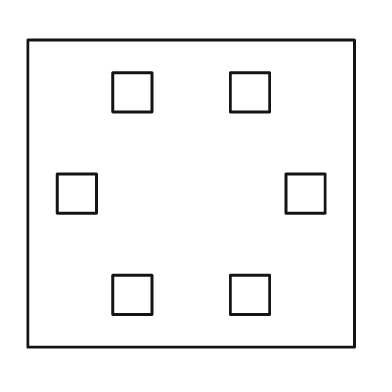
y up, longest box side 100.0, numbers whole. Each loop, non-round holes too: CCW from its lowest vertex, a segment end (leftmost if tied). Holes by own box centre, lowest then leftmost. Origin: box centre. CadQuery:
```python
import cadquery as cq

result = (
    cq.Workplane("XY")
    .moveTo(-50.0, -47.0)
    .lineTo(50.0, -47.0)
    .lineTo(50.0, 47.0)
    .lineTo(-50.0, 47.0)
    .close()
    .moveTo(-24.0, -37.0)
    .lineTo(-12.0, -37.0)
    .lineTo(-12.0, -25.0)
    .lineTo(-24.0, -25.0)
    .close()
    .moveTo(12.0, -37.0)
    .lineTo(24.0, -37.0)
    .lineTo(24.0, -25.0)
    .lineTo(12.0, -25.0)
    .close()
    .moveTo(-41.0, -6.0)
    .lineTo(-29.0, -6.0)
    .lineTo(-29.0, 6.0)
    .lineTo(-41.0, 6.0)
    .close()
    .moveTo(29.0, -6.0)
    .lineTo(41.0, -6.0)
    .lineTo(41.0, 6.0)
    .lineTo(29.0, 6.0)
    .close()
    .moveTo(-24.0, 25.0)
    .lineTo(-12.0, 25.0)
    .lineTo(-12.0, 37.0)
    .lineTo(-24.0, 37.0)
    .close()
    .moveTo(12.0, 25.0)
    .lineTo(24.0, 25.0)
    .lineTo(24.0, 37.0)
    .lineTo(12.0, 37.0)
    .close()
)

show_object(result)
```